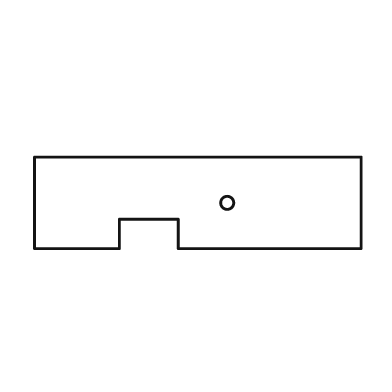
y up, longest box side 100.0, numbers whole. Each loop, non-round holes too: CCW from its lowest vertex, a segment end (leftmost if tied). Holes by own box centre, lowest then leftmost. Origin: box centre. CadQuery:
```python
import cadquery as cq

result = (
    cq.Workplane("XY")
    .moveTo(-50.0, -14.0)
    .lineTo(-24.0, -14.0)
    .lineTo(-24.0, -5.0)
    .lineTo(-6.0, -5.0)
    .lineTo(-6.0, -14.0)
    .lineTo(50.0, -14.0)
    .lineTo(50.0, 14.0)
    .lineTo(-50.0, 14.0)
    .close()
    .moveTo(9.0, 0.0)
    .circle(2.0)
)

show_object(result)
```